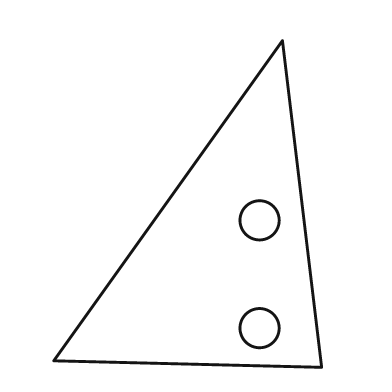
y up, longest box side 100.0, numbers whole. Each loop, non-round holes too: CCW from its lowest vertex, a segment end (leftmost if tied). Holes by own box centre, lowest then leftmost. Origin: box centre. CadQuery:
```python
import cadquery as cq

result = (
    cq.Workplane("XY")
    .moveTo(41.0, -50.0)
    .lineTo(29.0, 50.0)
    .lineTo(-41.0, -48.0)
    .close()
    .moveTo(22.0, -38.0)
    .circle(6.0)
    .moveTo(22.0, -5.0)
    .circle(6.0)
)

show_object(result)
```